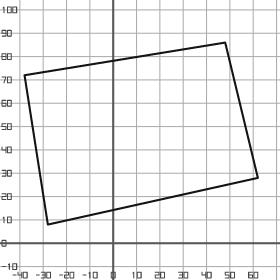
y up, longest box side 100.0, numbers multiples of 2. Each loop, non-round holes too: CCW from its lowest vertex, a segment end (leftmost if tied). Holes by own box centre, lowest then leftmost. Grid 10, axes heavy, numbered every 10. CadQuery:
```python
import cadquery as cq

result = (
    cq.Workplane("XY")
    .moveTo(-28.0, 8.0)
    .lineTo(62.0, 28.0)
    .lineTo(48.0, 86.0)
    .lineTo(-38.0, 72.0)
    .close()
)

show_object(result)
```